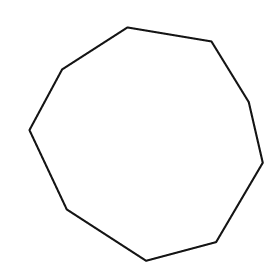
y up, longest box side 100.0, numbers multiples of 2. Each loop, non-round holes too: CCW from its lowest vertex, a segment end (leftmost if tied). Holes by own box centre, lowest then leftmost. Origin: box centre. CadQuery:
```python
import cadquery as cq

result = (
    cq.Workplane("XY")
    .moveTo(0.0, -50.0)
    .lineTo(30.0, -42.0)
    .lineTo(50.0, -8.0)
    .lineTo(44.0, 18.0)
    .lineTo(28.0, 44.0)
    .lineTo(-8.0, 50.0)
    .lineTo(-36.0, 32.0)
    .lineTo(-50.0, 6.0)
    .lineTo(-34.0, -28.0)
    .close()
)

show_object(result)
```